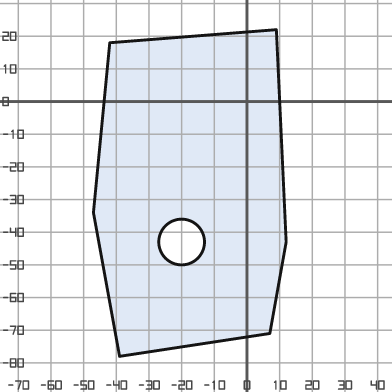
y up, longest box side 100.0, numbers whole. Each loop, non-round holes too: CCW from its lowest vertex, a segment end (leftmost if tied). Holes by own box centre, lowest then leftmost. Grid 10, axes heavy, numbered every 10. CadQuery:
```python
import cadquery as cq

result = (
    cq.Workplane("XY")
    .moveTo(-39.0, -78.0)
    .lineTo(7.0, -71.0)
    .lineTo(12.0, -43.0)
    .lineTo(9.0, 22.0)
    .lineTo(-42.0, 18.0)
    .lineTo(-47.0, -34.0)
    .close()
    .moveTo(-20.0, -43.0)
    .circle(7.0)
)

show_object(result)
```